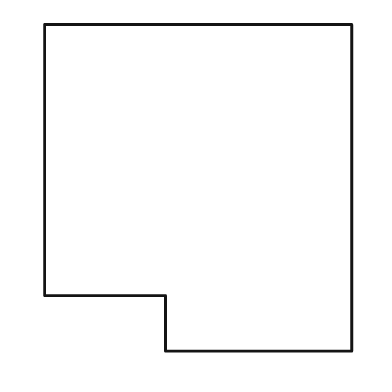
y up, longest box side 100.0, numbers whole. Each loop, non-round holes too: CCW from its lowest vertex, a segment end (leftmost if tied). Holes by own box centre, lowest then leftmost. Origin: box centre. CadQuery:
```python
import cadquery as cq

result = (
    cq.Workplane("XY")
    .moveTo(-10.0, -50.0)
    .lineTo(47.0, -50.0)
    .lineTo(47.0, 50.0)
    .lineTo(-47.0, 50.0)
    .lineTo(-47.0, -33.0)
    .lineTo(-10.0, -33.0)
    .close()
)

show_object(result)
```